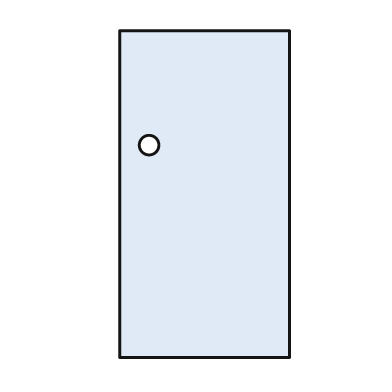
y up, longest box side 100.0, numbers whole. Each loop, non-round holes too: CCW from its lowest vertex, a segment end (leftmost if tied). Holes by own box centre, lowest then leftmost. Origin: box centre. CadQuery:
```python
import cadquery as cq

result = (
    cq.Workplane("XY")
    .moveTo(-26.0, -50.0)
    .lineTo(26.0, -50.0)
    .lineTo(26.0, 50.0)
    .lineTo(-26.0, 50.0)
    .close()
    .moveTo(-17.0, 15.0)
    .circle(3.0)
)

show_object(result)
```